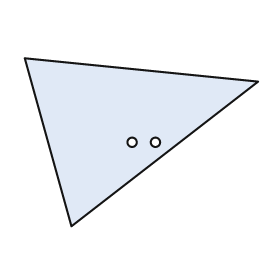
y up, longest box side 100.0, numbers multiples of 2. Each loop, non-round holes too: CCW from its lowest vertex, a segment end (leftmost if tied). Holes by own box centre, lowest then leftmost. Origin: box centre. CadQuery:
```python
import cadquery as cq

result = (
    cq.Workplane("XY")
    .moveTo(-30.0, -36.0)
    .lineTo(50.0, 26.0)
    .lineTo(-50.0, 36.0)
    .close()
    .moveTo(-4.0, 0.0)
    .circle(2.0)
    .moveTo(6.0, 0.0)
    .circle(2.0)
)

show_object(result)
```